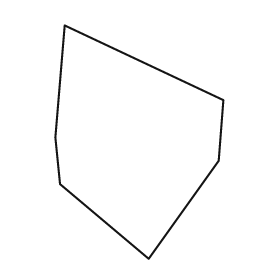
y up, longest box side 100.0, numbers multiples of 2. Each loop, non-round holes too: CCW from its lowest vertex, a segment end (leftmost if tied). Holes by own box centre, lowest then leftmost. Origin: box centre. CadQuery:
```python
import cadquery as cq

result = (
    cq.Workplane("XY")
    .moveTo(4.0, -50.0)
    .lineTo(34.0, -8.0)
    .lineTo(36.0, 18.0)
    .lineTo(-32.0, 50.0)
    .lineTo(-36.0, 2.0)
    .lineTo(-34.0, -18.0)
    .close()
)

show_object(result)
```